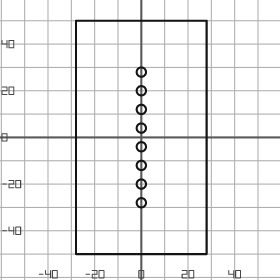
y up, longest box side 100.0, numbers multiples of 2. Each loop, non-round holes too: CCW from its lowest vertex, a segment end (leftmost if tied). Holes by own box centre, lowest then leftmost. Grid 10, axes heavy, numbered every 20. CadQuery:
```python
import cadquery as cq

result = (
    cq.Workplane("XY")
    .moveTo(-28.0, -50.0)
    .lineTo(28.0, -50.0)
    .lineTo(28.0, 50.0)
    .lineTo(-28.0, 50.0)
    .close()
    .moveTo(0.0, -28.0)
    .circle(2.0)
    .moveTo(0.0, -20.0)
    .circle(2.0)
    .moveTo(0.0, -12.0)
    .circle(2.0)
    .moveTo(0.0, -4.0)
    .circle(2.0)
    .moveTo(0.0, 4.0)
    .circle(2.0)
    .moveTo(0.0, 12.0)
    .circle(2.0)
    .moveTo(0.0, 20.0)
    .circle(2.0)
    .moveTo(0.0, 28.0)
    .circle(2.0)
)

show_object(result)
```